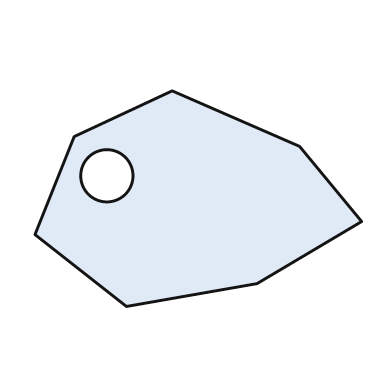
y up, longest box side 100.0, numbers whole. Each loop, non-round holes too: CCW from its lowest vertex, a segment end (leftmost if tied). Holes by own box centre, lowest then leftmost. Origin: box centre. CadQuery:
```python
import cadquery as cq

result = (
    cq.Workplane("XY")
    .moveTo(-22.0, -33.0)
    .lineTo(18.0, -26.0)
    .lineTo(50.0, -7.0)
    .lineTo(31.0, 16.0)
    .lineTo(-8.0, 33.0)
    .lineTo(-38.0, 19.0)
    .lineTo(-50.0, -11.0)
    .close()
    .moveTo(-28.0, 7.0)
    .circle(8.0)
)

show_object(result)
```